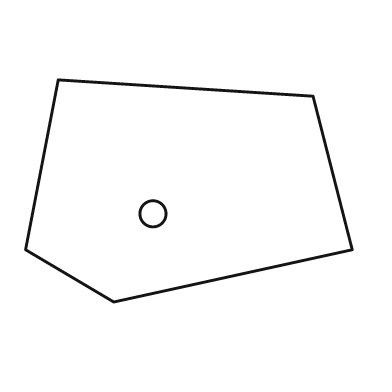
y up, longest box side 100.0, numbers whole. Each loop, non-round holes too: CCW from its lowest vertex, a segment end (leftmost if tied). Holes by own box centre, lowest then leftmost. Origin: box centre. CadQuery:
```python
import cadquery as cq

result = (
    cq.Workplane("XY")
    .moveTo(-23.0, -34.0)
    .lineTo(50.0, -18.0)
    .lineTo(38.0, 29.0)
    .lineTo(-40.0, 34.0)
    .lineTo(-50.0, -18.0)
    .close()
    .moveTo(-11.0, -7.0)
    .circle(4.0)
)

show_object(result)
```